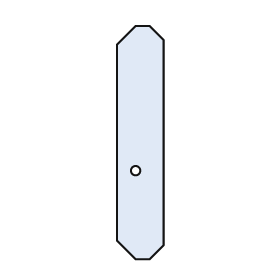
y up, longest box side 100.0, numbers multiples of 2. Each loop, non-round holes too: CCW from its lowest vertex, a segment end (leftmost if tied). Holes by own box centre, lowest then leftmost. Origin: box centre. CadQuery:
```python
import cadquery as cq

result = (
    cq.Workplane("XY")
    .moveTo(-2.0, -50.0)
    .lineTo(4.0, -50.0)
    .lineTo(10.0, -44.0)
    .lineTo(10.0, 44.0)
    .lineTo(4.0, 50.0)
    .lineTo(-2.0, 50.0)
    .lineTo(-10.0, 42.0)
    .lineTo(-10.0, -42.0)
    .close()
    .moveTo(-2.0, -12.0)
    .circle(2.0)
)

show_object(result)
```